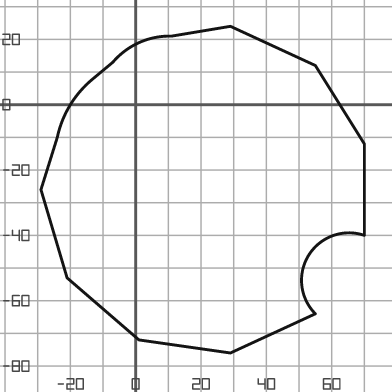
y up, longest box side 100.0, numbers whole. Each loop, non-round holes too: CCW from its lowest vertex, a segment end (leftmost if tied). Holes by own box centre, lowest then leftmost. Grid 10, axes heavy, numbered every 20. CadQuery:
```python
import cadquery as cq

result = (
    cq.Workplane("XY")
    .moveTo(29.0, -76.0)
    .lineTo(55.0, -64.0)
    .threePointArc((53.0, -46.0), (70.0, -40.0))
    .lineTo(70.0, -12.0)
    .lineTo(55.0, 12.0)
    .lineTo(29.0, 24.0)
    .lineTo(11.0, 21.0)
    .threePointArc((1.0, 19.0), (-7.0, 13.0))
    .lineTo(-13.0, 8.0)
    .threePointArc((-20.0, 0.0), (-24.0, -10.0))
    .lineTo(-29.0, -26.0)
    .lineTo(-21.0, -53.0)
    .lineTo(1.0, -72.0)
    .close()
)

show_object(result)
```